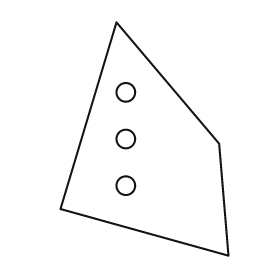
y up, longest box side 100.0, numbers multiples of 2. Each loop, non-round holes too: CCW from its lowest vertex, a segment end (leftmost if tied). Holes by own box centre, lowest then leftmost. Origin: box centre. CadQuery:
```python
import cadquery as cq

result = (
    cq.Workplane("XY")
    .moveTo(36.0, -50.0)
    .lineTo(32.0, -2.0)
    .lineTo(-12.0, 50.0)
    .lineTo(-36.0, -30.0)
    .close()
    .moveTo(-8.0, -20.0)
    .circle(4.0)
    .moveTo(-8.0, 0.0)
    .circle(4.0)
    .moveTo(-8.0, 20.0)
    .circle(4.0)
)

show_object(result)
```